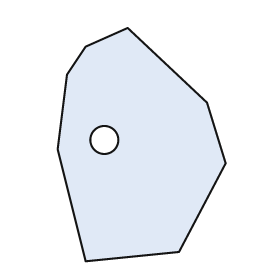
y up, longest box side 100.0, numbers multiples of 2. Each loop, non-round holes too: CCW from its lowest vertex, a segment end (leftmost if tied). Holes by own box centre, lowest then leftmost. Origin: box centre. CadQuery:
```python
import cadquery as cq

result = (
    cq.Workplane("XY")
    .moveTo(-24.0, -50.0)
    .lineTo(16.0, -46.0)
    .lineTo(36.0, -8.0)
    .lineTo(28.0, 18.0)
    .lineTo(-6.0, 50.0)
    .lineTo(-24.0, 42.0)
    .lineTo(-32.0, 30.0)
    .lineTo(-36.0, -2.0)
    .close()
    .moveTo(-16.0, 2.0)
    .circle(6.0)
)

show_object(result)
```